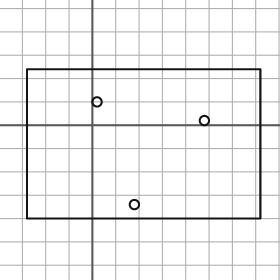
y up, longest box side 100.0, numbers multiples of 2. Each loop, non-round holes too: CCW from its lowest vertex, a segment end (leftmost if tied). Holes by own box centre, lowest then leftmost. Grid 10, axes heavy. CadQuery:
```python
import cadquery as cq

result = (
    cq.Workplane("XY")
    .moveTo(-28.0, -40.0)
    .lineTo(72.0, -40.0)
    .lineTo(72.0, 24.0)
    .lineTo(-28.0, 24.0)
    .close()
    .moveTo(18.0, -34.0)
    .circle(2.0)
    .moveTo(48.0, 2.0)
    .circle(2.0)
    .moveTo(2.0, 10.0)
    .circle(2.0)
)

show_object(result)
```